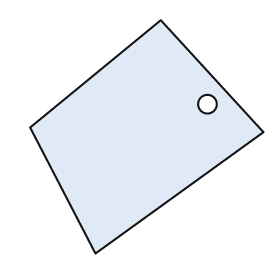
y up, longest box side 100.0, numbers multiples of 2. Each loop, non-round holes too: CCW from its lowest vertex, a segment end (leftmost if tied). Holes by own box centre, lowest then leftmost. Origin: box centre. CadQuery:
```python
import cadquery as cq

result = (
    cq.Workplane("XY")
    .moveTo(-22.0, -50.0)
    .lineTo(50.0, 2.0)
    .lineTo(6.0, 50.0)
    .lineTo(-50.0, 4.0)
    .close()
    .moveTo(26.0, 14.0)
    .circle(4.0)
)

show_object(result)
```